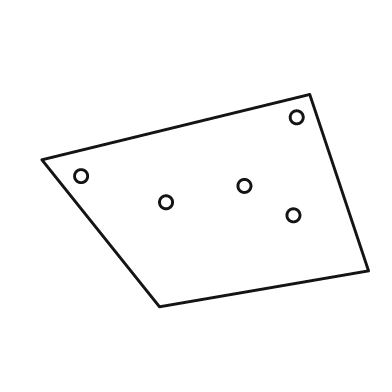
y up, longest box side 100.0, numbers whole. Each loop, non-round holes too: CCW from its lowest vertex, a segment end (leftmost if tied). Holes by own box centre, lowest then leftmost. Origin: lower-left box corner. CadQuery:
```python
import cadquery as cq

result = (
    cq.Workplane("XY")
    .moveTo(36.0, 0.0)
    .lineTo(100.0, 11.0)
    .lineTo(82.0, 65.0)
    .lineTo(0.0, 45.0)
    .close()
    .moveTo(77.0, 28.0)
    .circle(2.0)
    .moveTo(38.0, 32.0)
    .circle(2.0)
    .moveTo(62.0, 37.0)
    .circle(2.0)
    .moveTo(12.0, 40.0)
    .circle(2.0)
    .moveTo(78.0, 58.0)
    .circle(2.0)
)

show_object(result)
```